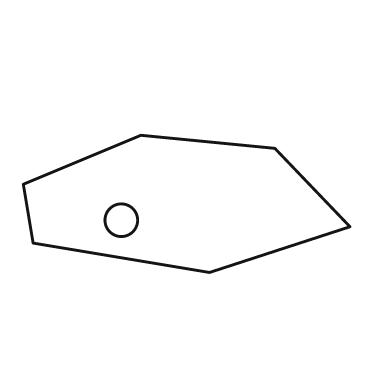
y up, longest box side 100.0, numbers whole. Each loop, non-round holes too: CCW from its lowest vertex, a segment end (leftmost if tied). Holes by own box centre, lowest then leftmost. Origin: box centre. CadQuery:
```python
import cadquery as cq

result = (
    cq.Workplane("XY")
    .moveTo(7.0, -21.0)
    .lineTo(50.0, -7.0)
    .lineTo(27.0, 17.0)
    .lineTo(-14.0, 21.0)
    .lineTo(-50.0, 6.0)
    .lineTo(-47.0, -12.0)
    .close()
    .moveTo(-20.0, -5.0)
    .circle(5.0)
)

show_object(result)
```